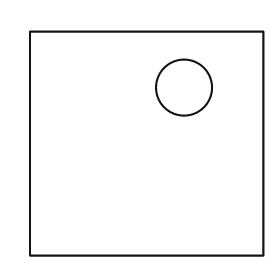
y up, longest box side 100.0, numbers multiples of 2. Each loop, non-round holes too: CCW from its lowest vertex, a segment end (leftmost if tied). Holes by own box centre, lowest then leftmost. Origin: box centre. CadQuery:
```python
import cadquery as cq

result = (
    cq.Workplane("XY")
    .moveTo(-50.0, -48.0)
    .lineTo(50.0, -48.0)
    .lineTo(50.0, 48.0)
    .lineTo(-50.0, 48.0)
    .close()
    .moveTo(16.0, 24.0)
    .circle(12.0)
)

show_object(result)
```